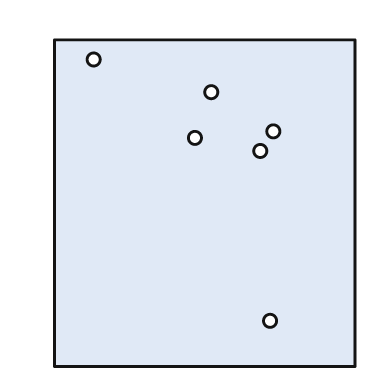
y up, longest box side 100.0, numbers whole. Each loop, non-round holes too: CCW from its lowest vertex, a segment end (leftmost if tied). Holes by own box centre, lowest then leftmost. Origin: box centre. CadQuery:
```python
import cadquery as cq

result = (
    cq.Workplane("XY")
    .moveTo(-46.0, -50.0)
    .lineTo(46.0, -50.0)
    .lineTo(46.0, 50.0)
    .lineTo(-46.0, 50.0)
    .close()
    .moveTo(20.0, -36.0)
    .circle(2.0)
    .moveTo(17.0, 16.0)
    .circle(2.0)
    .moveTo(-3.0, 20.0)
    .circle(2.0)
    .moveTo(21.0, 22.0)
    .circle(2.0)
    .moveTo(2.0, 34.0)
    .circle(2.0)
    .moveTo(-34.0, 44.0)
    .circle(2.0)
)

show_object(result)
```